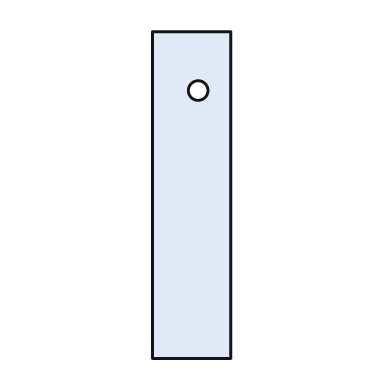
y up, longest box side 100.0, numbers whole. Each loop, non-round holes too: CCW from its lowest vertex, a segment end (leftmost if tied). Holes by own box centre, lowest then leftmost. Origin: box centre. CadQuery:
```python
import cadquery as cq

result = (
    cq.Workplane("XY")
    .moveTo(-12.0, -50.0)
    .lineTo(12.0, -50.0)
    .lineTo(12.0, 50.0)
    .lineTo(-12.0, 50.0)
    .close()
    .moveTo(2.0, 32.0)
    .circle(3.0)
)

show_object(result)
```